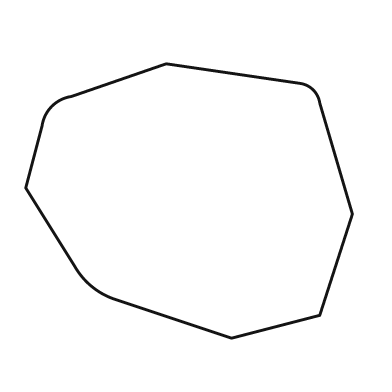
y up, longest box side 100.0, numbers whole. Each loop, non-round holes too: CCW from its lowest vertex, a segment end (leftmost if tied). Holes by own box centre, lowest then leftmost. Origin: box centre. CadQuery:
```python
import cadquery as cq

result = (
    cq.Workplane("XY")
    .moveTo(13.0, -42.0)
    .lineTo(40.0, -35.0)
    .lineTo(50.0, -4.0)
    .lineTo(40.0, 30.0)
    .threePointArc((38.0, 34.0), (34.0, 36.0))
    .lineTo(-7.0, 42.0)
    .lineTo(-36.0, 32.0)
    .threePointArc((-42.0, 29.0), (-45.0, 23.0))
    .lineTo(-50.0, 4.0)
    .lineTo(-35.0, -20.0)
    .threePointArc((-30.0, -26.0), (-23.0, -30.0))
    .close()
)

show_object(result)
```